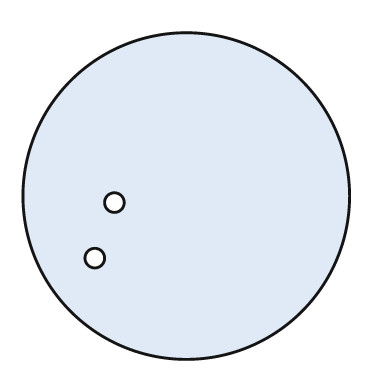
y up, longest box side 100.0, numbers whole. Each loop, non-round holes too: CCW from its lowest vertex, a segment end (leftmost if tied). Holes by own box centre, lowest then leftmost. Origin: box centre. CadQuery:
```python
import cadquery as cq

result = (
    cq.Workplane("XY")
    .moveTo(0.0, 0.0)
    .circle(50.0)
    .moveTo(-28.0, -19.0)
    .circle(3.0)
    .moveTo(-22.0, -2.0)
    .circle(3.0)
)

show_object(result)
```